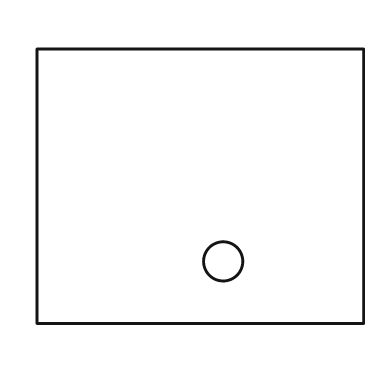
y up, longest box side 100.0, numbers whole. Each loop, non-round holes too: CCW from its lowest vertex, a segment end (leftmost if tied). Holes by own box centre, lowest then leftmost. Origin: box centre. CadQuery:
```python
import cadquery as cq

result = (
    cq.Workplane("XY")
    .moveTo(-50.0, -42.0)
    .lineTo(50.0, -42.0)
    .lineTo(50.0, 42.0)
    .lineTo(-50.0, 42.0)
    .close()
    .moveTo(7.0, -23.0)
    .circle(6.0)
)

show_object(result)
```